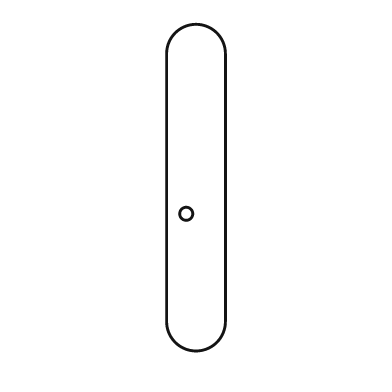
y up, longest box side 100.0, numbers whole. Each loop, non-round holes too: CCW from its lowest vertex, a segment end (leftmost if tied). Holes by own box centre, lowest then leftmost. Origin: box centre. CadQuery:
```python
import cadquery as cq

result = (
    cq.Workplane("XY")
    .moveTo(-9.0, -41.0)
    .threePointArc((0.0, -50.0), (9.0, -41.0))
    .lineTo(9.0, 41.0)
    .threePointArc((0.0, 50.0), (-9.0, 41.0))
    .close()
    .moveTo(-3.0, -8.0)
    .circle(2.0)
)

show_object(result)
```